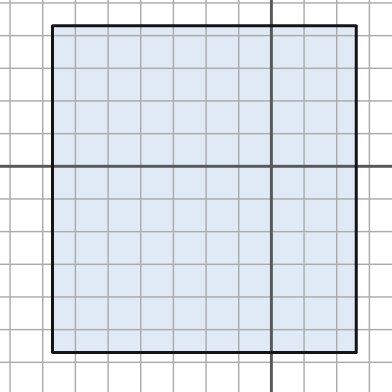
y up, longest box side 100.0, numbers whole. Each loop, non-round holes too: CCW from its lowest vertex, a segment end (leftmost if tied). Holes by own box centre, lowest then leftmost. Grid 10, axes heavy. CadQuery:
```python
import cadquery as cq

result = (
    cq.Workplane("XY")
    .moveTo(-67.0, -57.0)
    .lineTo(26.0, -57.0)
    .lineTo(26.0, 43.0)
    .lineTo(-67.0, 43.0)
    .close()
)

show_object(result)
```